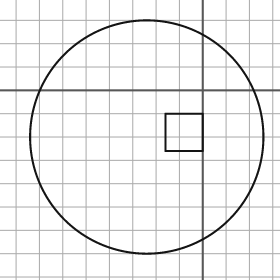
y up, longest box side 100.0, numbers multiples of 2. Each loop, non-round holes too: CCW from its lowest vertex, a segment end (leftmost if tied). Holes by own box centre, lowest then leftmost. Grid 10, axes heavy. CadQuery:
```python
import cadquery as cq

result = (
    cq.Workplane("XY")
    .moveTo(-24.0, -20.0)
    .circle(50.0)
    .moveTo(-16.0, -26.0)
    .lineTo(0.0, -26.0)
    .lineTo(0.0, -10.0)
    .lineTo(-16.0, -10.0)
    .close()
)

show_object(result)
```